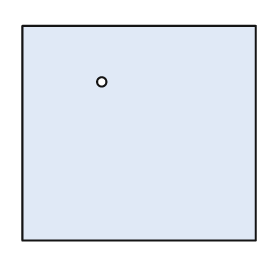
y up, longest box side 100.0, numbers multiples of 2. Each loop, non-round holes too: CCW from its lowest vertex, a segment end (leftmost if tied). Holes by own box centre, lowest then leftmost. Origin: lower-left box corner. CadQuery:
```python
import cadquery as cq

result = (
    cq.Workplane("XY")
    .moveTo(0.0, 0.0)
    .lineTo(100.0, 0.0)
    .lineTo(100.0, 92.0)
    .lineTo(0.0, 92.0)
    .close()
    .moveTo(34.0, 68.0)
    .circle(2.0)
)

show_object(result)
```